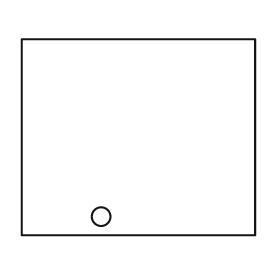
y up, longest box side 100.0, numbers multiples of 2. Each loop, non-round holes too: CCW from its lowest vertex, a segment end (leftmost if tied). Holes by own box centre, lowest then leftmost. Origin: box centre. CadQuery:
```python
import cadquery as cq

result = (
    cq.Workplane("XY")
    .moveTo(-50.0, -42.0)
    .lineTo(50.0, -42.0)
    .lineTo(50.0, 42.0)
    .lineTo(-50.0, 42.0)
    .close()
    .moveTo(-16.0, -34.0)
    .circle(4.0)
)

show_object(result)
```